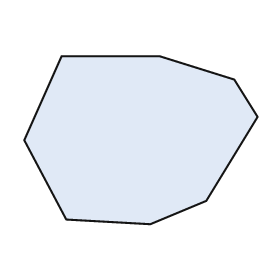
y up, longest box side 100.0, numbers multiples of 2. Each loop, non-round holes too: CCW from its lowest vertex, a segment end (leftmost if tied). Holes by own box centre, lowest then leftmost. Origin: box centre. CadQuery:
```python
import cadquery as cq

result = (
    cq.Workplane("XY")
    .moveTo(4.0, -36.0)
    .lineTo(28.0, -26.0)
    .lineTo(50.0, 10.0)
    .lineTo(40.0, 26.0)
    .lineTo(8.0, 36.0)
    .lineTo(-34.0, 36.0)
    .lineTo(-50.0, 0.0)
    .lineTo(-32.0, -34.0)
    .close()
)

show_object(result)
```